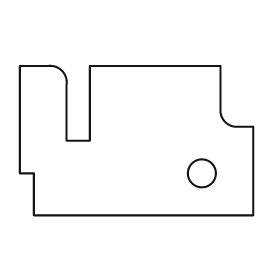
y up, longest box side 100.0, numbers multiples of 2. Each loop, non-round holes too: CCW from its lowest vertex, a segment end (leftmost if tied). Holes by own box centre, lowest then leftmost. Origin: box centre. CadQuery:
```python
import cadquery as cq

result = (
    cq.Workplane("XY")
    .moveTo(-44.0, -32.0)
    .lineTo(50.0, -32.0)
    .lineTo(50.0, 6.0)
    .lineTo(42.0, 6.0)
    .threePointArc((38.0, 8.0), (36.0, 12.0))
    .lineTo(36.0, 32.0)
    .lineTo(-20.0, 32.0)
    .lineTo(-20.0, 0.0)
    .lineTo(-30.0, 0.0)
    .lineTo(-30.0, 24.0)
    .threePointArc((-32.0, 30.0), (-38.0, 32.0))
    .lineTo(-50.0, 32.0)
    .lineTo(-50.0, -14.0)
    .lineTo(-44.0, -14.0)
    .close()
    .moveTo(28.0, -14.0)
    .circle(6.0)
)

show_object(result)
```